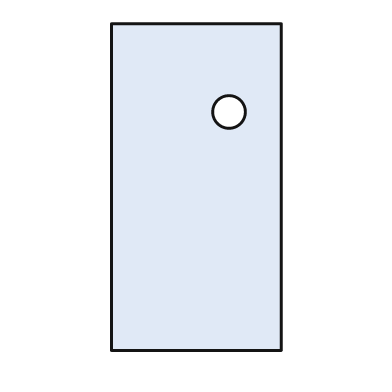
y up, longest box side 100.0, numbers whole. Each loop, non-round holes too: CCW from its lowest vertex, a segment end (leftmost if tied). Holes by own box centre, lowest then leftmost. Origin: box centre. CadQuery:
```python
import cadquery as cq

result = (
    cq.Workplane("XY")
    .moveTo(-26.0, -50.0)
    .lineTo(26.0, -50.0)
    .lineTo(26.0, 50.0)
    .lineTo(-26.0, 50.0)
    .close()
    .moveTo(10.0, 23.0)
    .circle(5.0)
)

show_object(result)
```